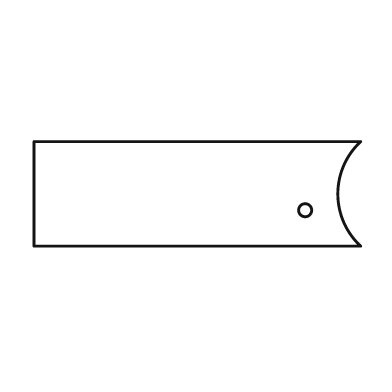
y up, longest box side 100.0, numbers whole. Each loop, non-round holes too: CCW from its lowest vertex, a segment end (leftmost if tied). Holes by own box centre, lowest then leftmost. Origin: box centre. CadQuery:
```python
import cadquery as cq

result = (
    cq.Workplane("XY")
    .moveTo(-50.0, -16.0)
    .lineTo(50.0, -16.0)
    .threePointArc((43.0, 0.0), (50.0, 16.0))
    .lineTo(-50.0, 16.0)
    .close()
    .moveTo(33.0, -5.0)
    .circle(2.0)
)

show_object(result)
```